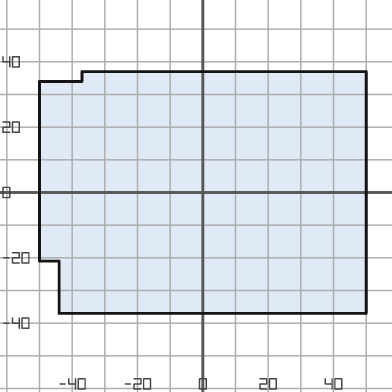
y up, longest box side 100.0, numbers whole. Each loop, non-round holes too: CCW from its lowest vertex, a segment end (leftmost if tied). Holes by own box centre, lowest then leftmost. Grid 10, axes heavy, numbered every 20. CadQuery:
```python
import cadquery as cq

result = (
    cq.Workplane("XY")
    .moveTo(-44.0, -37.0)
    .lineTo(50.0, -37.0)
    .lineTo(50.0, 37.0)
    .lineTo(-37.0, 37.0)
    .lineTo(-37.0, 34.0)
    .lineTo(-50.0, 34.0)
    .lineTo(-50.0, -21.0)
    .lineTo(-44.0, -21.0)
    .close()
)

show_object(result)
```